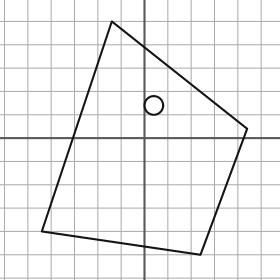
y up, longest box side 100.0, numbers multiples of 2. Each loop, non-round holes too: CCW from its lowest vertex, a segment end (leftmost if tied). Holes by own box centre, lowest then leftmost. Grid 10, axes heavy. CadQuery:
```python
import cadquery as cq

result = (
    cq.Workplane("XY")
    .moveTo(24.0, -50.0)
    .lineTo(44.0, 4.0)
    .lineTo(-14.0, 50.0)
    .lineTo(-44.0, -40.0)
    .close()
    .moveTo(4.0, 14.0)
    .circle(4.0)
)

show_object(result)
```